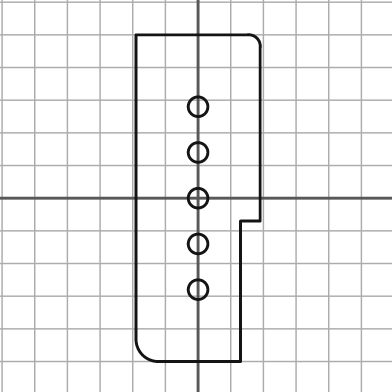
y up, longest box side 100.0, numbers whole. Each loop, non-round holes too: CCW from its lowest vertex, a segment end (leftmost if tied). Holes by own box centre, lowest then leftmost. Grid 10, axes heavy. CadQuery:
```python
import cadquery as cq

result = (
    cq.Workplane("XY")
    .moveTo(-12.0, -50.0)
    .lineTo(13.0, -50.0)
    .lineTo(13.0, -7.0)
    .lineTo(19.0, -7.0)
    .lineTo(19.0, 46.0)
    .threePointArc((18.0, 49.0), (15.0, 50.0))
    .lineTo(-19.0, 50.0)
    .lineTo(-19.0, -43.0)
    .threePointArc((-17.0, -48.0), (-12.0, -50.0))
    .close()
    .moveTo(0.0, -28.0)
    .circle(3.0)
    .moveTo(0.0, -14.0)
    .circle(3.0)
    .moveTo(0.0, 0.0)
    .circle(3.0)
    .moveTo(0.0, 14.0)
    .circle(3.0)
    .moveTo(0.0, 28.0)
    .circle(3.0)
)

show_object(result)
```